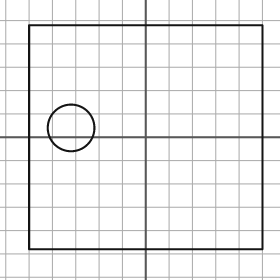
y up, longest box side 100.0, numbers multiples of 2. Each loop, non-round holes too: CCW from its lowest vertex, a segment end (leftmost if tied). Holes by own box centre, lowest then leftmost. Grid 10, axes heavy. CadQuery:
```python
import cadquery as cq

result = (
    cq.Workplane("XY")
    .moveTo(-50.0, -48.0)
    .lineTo(50.0, -48.0)
    .lineTo(50.0, 48.0)
    .lineTo(-50.0, 48.0)
    .close()
    .moveTo(-32.0, 4.0)
    .circle(10.0)
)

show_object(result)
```